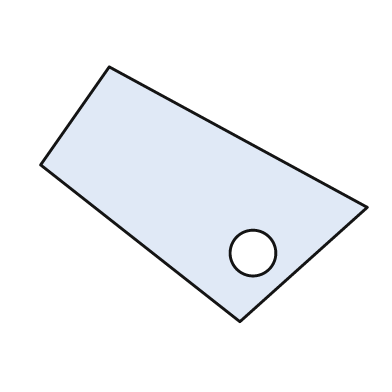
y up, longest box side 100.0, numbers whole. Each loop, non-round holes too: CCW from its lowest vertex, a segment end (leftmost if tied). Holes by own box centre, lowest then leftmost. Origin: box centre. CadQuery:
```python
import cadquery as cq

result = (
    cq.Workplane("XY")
    .moveTo(11.0, -39.0)
    .lineTo(50.0, -4.0)
    .lineTo(-29.0, 39.0)
    .lineTo(-50.0, 9.0)
    .close()
    .moveTo(15.0, -18.0)
    .circle(7.0)
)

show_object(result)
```